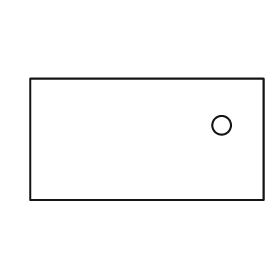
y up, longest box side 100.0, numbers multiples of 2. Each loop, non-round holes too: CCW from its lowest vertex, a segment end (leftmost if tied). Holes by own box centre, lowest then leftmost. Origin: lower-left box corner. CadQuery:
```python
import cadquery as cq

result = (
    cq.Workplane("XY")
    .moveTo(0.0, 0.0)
    .lineTo(100.0, 0.0)
    .lineTo(100.0, 52.0)
    .lineTo(0.0, 52.0)
    .close()
    .moveTo(82.0, 32.0)
    .circle(4.0)
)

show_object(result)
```